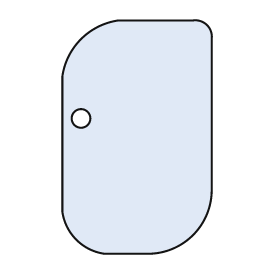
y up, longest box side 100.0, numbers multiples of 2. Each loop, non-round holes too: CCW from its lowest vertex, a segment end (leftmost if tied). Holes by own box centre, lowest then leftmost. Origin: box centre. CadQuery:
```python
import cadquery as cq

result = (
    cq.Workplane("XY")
    .moveTo(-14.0, -50.0)
    .lineTo(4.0, -50.0)
    .threePointArc((24.0, -42.0), (32.0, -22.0))
    .lineTo(32.0, 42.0)
    .threePointArc((30.0, 48.0), (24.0, 50.0))
    .lineTo(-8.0, 50.0)
    .threePointArc((-24.0, 42.0), (-32.0, 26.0))
    .lineTo(-32.0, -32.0)
    .threePointArc((-26.0, -44.0), (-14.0, -50.0))
    .close()
    .moveTo(-24.0, 8.0)
    .circle(4.0)
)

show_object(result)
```